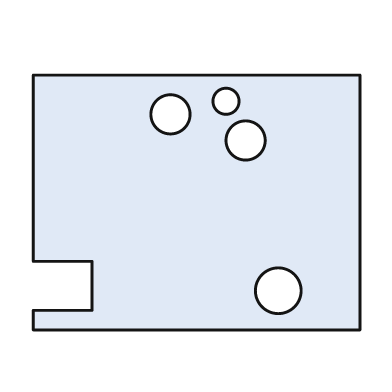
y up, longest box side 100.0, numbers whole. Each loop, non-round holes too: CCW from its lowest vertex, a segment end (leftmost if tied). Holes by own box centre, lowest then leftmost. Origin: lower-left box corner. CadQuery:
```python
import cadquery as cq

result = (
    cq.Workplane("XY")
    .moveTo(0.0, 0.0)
    .lineTo(100.0, 0.0)
    .lineTo(100.0, 78.0)
    .lineTo(0.0, 78.0)
    .lineTo(0.0, 21.0)
    .lineTo(18.0, 21.0)
    .lineTo(18.0, 6.0)
    .lineTo(0.0, 6.0)
    .close()
    .moveTo(75.0, 12.0)
    .circle(7.0)
    .moveTo(65.0, 58.0)
    .circle(6.0)
    .moveTo(42.0, 66.0)
    .circle(6.0)
    .moveTo(59.0, 70.0)
    .circle(4.0)
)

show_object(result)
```